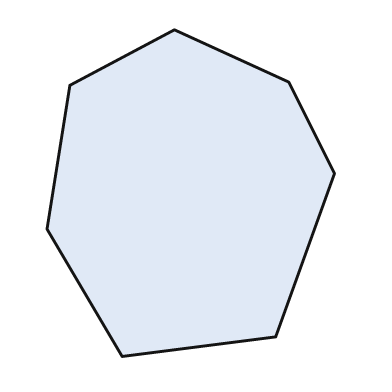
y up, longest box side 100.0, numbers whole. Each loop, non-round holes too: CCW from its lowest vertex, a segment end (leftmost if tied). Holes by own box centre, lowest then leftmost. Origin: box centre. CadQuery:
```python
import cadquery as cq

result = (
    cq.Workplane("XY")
    .moveTo(-21.0, -50.0)
    .lineTo(26.0, -44.0)
    .lineTo(44.0, 6.0)
    .lineTo(30.0, 34.0)
    .lineTo(-5.0, 50.0)
    .lineTo(-37.0, 33.0)
    .lineTo(-44.0, -11.0)
    .close()
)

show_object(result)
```